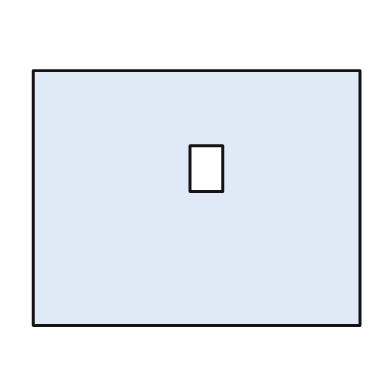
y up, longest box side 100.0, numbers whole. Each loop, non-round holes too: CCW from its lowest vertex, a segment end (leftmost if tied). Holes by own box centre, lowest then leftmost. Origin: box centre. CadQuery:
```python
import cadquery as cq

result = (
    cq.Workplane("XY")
    .moveTo(-50.0, -39.0)
    .lineTo(50.0, -39.0)
    .lineTo(50.0, 39.0)
    .lineTo(-50.0, 39.0)
    .close()
    .moveTo(-2.0, 2.0)
    .lineTo(8.0, 2.0)
    .lineTo(8.0, 16.0)
    .lineTo(-2.0, 16.0)
    .close()
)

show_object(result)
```